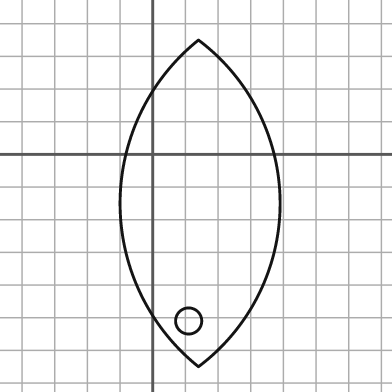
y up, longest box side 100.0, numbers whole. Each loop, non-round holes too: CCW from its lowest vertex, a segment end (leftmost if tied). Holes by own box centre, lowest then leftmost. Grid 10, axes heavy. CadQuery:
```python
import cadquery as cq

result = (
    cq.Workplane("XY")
    .moveTo(14.0, -65.0)
    .threePointArc((39.0, -15.0), (14.0, 35.0))
    .threePointArc((-10.0, -15.0), (14.0, -65.0))
    .close()
    .moveTo(11.0, -51.0)
    .circle(4.0)
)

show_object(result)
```